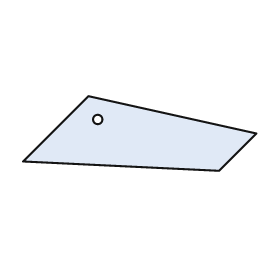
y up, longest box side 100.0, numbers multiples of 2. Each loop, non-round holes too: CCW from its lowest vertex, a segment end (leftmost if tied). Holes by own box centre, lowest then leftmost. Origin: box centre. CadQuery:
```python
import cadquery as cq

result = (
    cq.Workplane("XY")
    .moveTo(34.0, -16.0)
    .lineTo(50.0, 0.0)
    .lineTo(-22.0, 16.0)
    .lineTo(-50.0, -12.0)
    .close()
    .moveTo(-18.0, 6.0)
    .circle(2.0)
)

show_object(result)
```